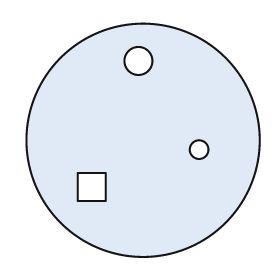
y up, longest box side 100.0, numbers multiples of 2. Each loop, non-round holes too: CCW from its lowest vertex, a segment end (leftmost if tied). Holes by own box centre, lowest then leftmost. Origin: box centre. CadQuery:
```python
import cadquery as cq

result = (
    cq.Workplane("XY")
    .moveTo(0.0, 0.0)
    .circle(50.0)
    .moveTo(-28.0, -26.0)
    .lineTo(-16.0, -26.0)
    .lineTo(-16.0, -14.0)
    .lineTo(-28.0, -14.0)
    .close()
    .moveTo(24.0, -4.0)
    .circle(4.0)
    .moveTo(-2.0, 34.0)
    .circle(6.0)
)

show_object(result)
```